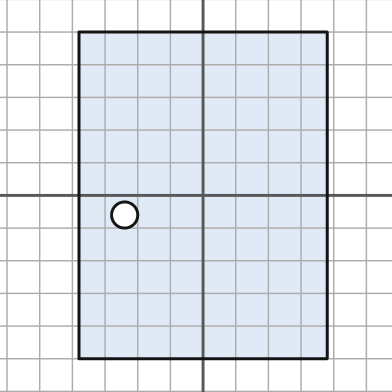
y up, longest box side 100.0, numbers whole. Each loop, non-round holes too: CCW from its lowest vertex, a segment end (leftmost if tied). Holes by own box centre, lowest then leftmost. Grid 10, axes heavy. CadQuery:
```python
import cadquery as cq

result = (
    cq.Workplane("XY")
    .moveTo(-38.0, -50.0)
    .lineTo(38.0, -50.0)
    .lineTo(38.0, 50.0)
    .lineTo(-38.0, 50.0)
    .close()
    .moveTo(-24.0, -6.0)
    .circle(4.0)
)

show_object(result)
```